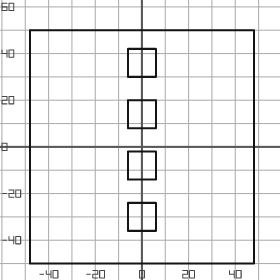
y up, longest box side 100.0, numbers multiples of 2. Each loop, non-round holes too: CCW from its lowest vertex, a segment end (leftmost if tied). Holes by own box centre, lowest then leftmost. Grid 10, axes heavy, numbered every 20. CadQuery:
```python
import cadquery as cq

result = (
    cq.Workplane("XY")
    .moveTo(-48.0, -50.0)
    .lineTo(48.0, -50.0)
    .lineTo(48.0, 50.0)
    .lineTo(-48.0, 50.0)
    .close()
    .moveTo(-6.0, -36.0)
    .lineTo(6.0, -36.0)
    .lineTo(6.0, -24.0)
    .lineTo(-6.0, -24.0)
    .close()
    .moveTo(-6.0, -14.0)
    .lineTo(6.0, -14.0)
    .lineTo(6.0, -2.0)
    .lineTo(-6.0, -2.0)
    .close()
    .moveTo(-6.0, 8.0)
    .lineTo(6.0, 8.0)
    .lineTo(6.0, 20.0)
    .lineTo(-6.0, 20.0)
    .close()
    .moveTo(-6.0, 30.0)
    .lineTo(6.0, 30.0)
    .lineTo(6.0, 42.0)
    .lineTo(-6.0, 42.0)
    .close()
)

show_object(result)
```